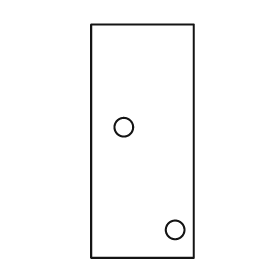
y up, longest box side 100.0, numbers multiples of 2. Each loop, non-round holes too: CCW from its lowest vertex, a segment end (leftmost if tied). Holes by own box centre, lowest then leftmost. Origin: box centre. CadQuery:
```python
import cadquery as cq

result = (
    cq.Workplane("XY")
    .moveTo(-22.0, -50.0)
    .lineTo(22.0, -50.0)
    .lineTo(22.0, 50.0)
    .lineTo(-22.0, 50.0)
    .close()
    .moveTo(14.0, -38.0)
    .circle(4.0)
    .moveTo(-8.0, 6.0)
    .circle(4.0)
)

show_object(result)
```